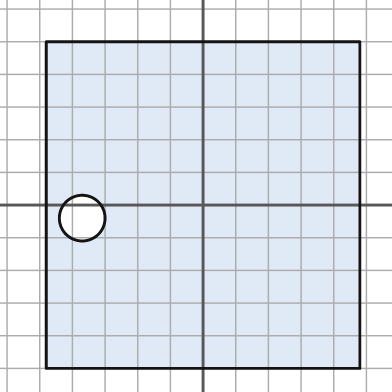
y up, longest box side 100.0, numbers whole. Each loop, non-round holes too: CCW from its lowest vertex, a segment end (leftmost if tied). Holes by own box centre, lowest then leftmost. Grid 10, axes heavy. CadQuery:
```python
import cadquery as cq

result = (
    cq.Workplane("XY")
    .moveTo(-48.0, -50.0)
    .lineTo(48.0, -50.0)
    .lineTo(48.0, 50.0)
    .lineTo(-48.0, 50.0)
    .close()
    .moveTo(-37.0, -4.0)
    .circle(7.0)
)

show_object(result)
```